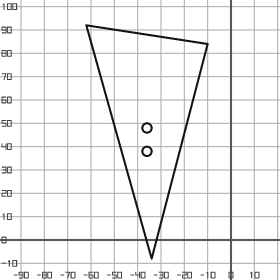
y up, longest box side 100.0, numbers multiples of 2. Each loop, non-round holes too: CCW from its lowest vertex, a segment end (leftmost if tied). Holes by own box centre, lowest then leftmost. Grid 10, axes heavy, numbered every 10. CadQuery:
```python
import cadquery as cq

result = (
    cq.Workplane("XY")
    .moveTo(-34.0, -8.0)
    .lineTo(-10.0, 84.0)
    .lineTo(-62.0, 92.0)
    .close()
    .moveTo(-36.0, 38.0)
    .circle(2.0)
    .moveTo(-36.0, 48.0)
    .circle(2.0)
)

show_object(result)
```